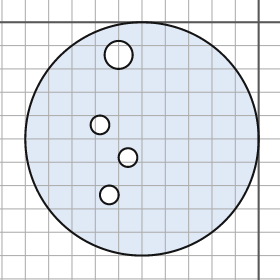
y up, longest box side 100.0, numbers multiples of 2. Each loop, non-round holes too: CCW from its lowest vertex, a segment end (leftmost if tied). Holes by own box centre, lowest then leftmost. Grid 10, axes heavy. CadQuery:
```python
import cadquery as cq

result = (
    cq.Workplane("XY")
    .moveTo(-50.0, -50.0)
    .circle(50.0)
    .moveTo(-64.0, -74.0)
    .circle(4.0)
    .moveTo(-56.0, -58.0)
    .circle(4.0)
    .moveTo(-68.0, -44.0)
    .circle(4.0)
    .moveTo(-60.0, -14.0)
    .circle(6.0)
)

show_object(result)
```